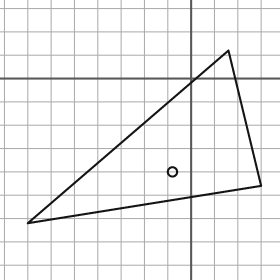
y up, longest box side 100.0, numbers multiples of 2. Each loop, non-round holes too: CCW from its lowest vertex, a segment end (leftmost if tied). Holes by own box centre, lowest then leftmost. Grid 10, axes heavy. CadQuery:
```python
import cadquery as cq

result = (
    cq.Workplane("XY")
    .moveTo(-70.0, -62.0)
    .lineTo(30.0, -46.0)
    .lineTo(16.0, 12.0)
    .close()
    .moveTo(-8.0, -40.0)
    .circle(2.0)
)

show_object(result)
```